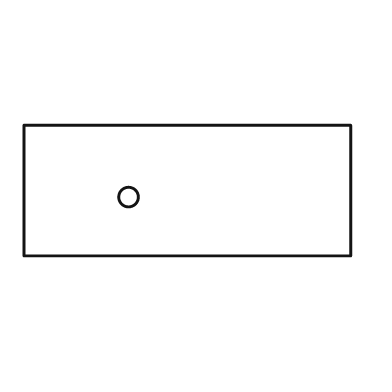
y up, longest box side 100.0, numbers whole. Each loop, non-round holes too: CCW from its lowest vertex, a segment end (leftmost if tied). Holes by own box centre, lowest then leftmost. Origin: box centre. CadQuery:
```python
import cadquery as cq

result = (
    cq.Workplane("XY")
    .moveTo(-50.0, -20.0)
    .lineTo(50.0, -20.0)
    .lineTo(50.0, 20.0)
    .lineTo(-50.0, 20.0)
    .close()
    .moveTo(-18.0, -2.0)
    .circle(3.0)
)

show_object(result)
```